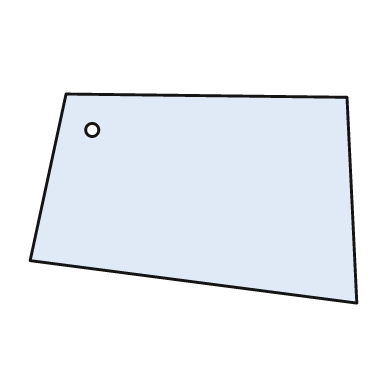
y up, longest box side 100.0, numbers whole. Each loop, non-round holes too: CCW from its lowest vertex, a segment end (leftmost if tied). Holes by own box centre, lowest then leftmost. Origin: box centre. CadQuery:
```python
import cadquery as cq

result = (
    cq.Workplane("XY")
    .moveTo(50.0, -32.0)
    .lineTo(47.0, 31.0)
    .lineTo(-39.0, 32.0)
    .lineTo(-50.0, -19.0)
    .close()
    .moveTo(-31.0, 21.0)
    .circle(2.0)
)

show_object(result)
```